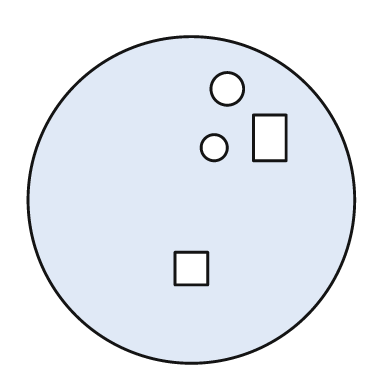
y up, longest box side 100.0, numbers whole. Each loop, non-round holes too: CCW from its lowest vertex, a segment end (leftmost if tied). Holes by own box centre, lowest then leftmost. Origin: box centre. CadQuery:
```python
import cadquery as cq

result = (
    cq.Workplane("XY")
    .moveTo(0.0, 0.0)
    .circle(50.0)
    .moveTo(-5.0, -26.0)
    .lineTo(5.0, -26.0)
    .lineTo(5.0, -16.0)
    .lineTo(-5.0, -16.0)
    .close()
    .moveTo(7.0, 16.0)
    .circle(4.0)
    .moveTo(19.0, 12.0)
    .lineTo(29.0, 12.0)
    .lineTo(29.0, 26.0)
    .lineTo(19.0, 26.0)
    .close()
    .moveTo(11.0, 34.0)
    .circle(5.0)
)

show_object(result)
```